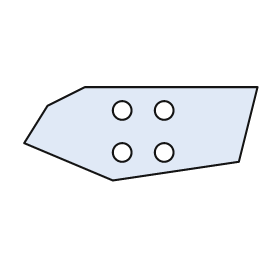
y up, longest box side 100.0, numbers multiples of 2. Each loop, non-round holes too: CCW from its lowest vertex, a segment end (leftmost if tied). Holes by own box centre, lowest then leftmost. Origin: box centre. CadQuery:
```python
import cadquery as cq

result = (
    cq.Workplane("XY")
    .moveTo(-12.0, -20.0)
    .lineTo(42.0, -12.0)
    .lineTo(50.0, 20.0)
    .lineTo(-24.0, 20.0)
    .lineTo(-40.0, 12.0)
    .lineTo(-50.0, -4.0)
    .close()
    .moveTo(-8.0, -8.0)
    .circle(4.0)
    .moveTo(10.0, -8.0)
    .circle(4.0)
    .moveTo(-8.0, 10.0)
    .circle(4.0)
    .moveTo(10.0, 10.0)
    .circle(4.0)
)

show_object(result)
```